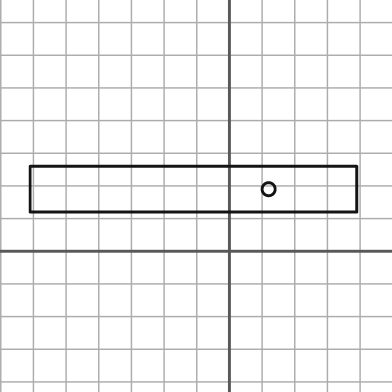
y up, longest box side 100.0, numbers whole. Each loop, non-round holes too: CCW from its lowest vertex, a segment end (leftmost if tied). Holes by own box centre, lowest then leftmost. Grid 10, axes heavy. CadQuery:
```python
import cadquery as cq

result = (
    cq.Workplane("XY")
    .moveTo(-61.0, 12.0)
    .lineTo(39.0, 12.0)
    .lineTo(39.0, 26.0)
    .lineTo(-61.0, 26.0)
    .close()
    .moveTo(12.0, 19.0)
    .circle(2.0)
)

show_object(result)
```